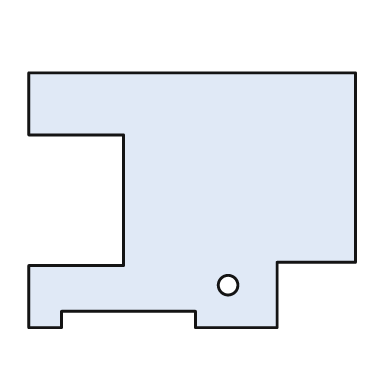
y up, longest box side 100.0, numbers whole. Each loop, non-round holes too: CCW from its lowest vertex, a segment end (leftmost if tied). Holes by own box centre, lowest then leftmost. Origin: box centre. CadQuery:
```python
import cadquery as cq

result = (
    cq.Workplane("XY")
    .moveTo(-50.0, -39.0)
    .lineTo(-40.0, -39.0)
    .lineTo(-40.0, -34.0)
    .lineTo(1.0, -34.0)
    .lineTo(1.0, -39.0)
    .lineTo(26.0, -39.0)
    .lineTo(26.0, -19.0)
    .lineTo(50.0, -19.0)
    .lineTo(50.0, 39.0)
    .lineTo(-50.0, 39.0)
    .lineTo(-50.0, 20.0)
    .lineTo(-21.0, 20.0)
    .lineTo(-21.0, -20.0)
    .lineTo(-50.0, -20.0)
    .close()
    .moveTo(11.0, -26.0)
    .circle(3.0)
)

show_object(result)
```